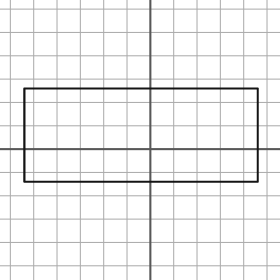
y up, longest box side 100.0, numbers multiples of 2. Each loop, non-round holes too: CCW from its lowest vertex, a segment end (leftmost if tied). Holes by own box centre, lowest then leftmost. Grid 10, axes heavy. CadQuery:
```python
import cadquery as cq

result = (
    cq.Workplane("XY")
    .moveTo(-54.0, -14.0)
    .lineTo(46.0, -14.0)
    .lineTo(46.0, 26.0)
    .lineTo(-54.0, 26.0)
    .close()
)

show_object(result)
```